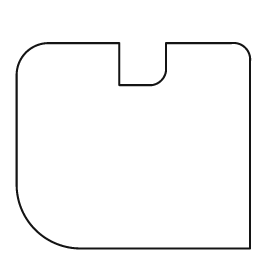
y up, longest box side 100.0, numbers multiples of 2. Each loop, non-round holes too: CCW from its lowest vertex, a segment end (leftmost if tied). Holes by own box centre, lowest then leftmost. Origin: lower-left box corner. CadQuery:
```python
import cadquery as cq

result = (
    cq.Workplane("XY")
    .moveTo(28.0, 0.0)
    .lineTo(100.0, 0.0)
    .lineTo(100.0, 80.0)
    .threePointArc((98.0, 86.0), (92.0, 88.0))
    .lineTo(64.0, 88.0)
    .lineTo(64.0, 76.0)
    .threePointArc((62.0, 72.0), (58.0, 70.0))
    .lineTo(44.0, 70.0)
    .lineTo(44.0, 88.0)
    .lineTo(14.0, 88.0)
    .threePointArc((4.0, 84.0), (0.0, 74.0))
    .lineTo(0.0, 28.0)
    .threePointArc((8.0, 8.0), (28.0, 0.0))
    .close()
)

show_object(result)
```